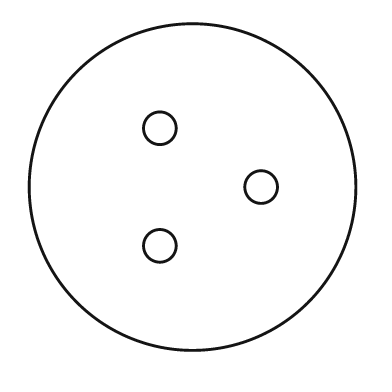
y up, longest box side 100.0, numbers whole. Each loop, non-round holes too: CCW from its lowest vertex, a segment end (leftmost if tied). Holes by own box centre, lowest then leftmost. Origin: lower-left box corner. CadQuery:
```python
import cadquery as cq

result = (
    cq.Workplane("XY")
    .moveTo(50.0, 50.0)
    .circle(50.0)
    .moveTo(40.0, 32.0)
    .circle(5.0)
    .moveTo(71.0, 50.0)
    .circle(5.0)
    .moveTo(40.0, 68.0)
    .circle(5.0)
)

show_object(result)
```